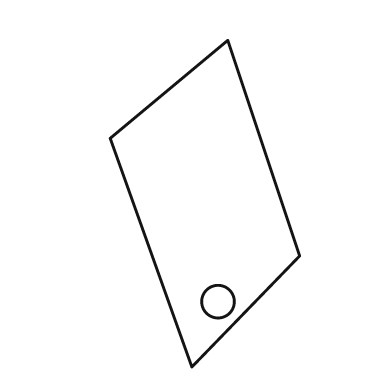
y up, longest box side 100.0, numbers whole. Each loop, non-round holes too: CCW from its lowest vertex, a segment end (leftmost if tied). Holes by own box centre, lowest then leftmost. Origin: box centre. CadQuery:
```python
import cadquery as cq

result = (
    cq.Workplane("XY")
    .moveTo(-4.0, -50.0)
    .lineTo(29.0, -16.0)
    .lineTo(7.0, 50.0)
    .lineTo(-29.0, 20.0)
    .close()
    .moveTo(4.0, -30.0)
    .circle(5.0)
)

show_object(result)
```